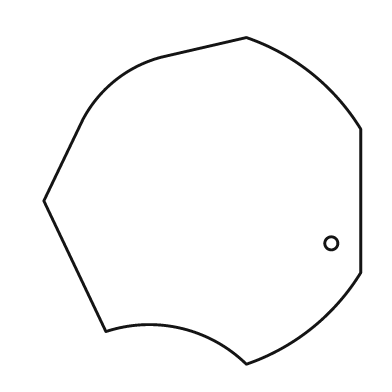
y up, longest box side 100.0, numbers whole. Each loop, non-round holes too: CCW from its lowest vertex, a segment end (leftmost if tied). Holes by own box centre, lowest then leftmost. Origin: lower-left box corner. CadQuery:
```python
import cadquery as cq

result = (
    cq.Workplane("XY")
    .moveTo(62.0, 0.0)
    .threePointArc((82.0, 11.0), (97.0, 28.0))
    .lineTo(97.0, 72.0)
    .threePointArc((82.0, 89.0), (62.0, 100.0))
    .lineTo(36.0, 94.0)
    .threePointArc((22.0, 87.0), (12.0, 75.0))
    .lineTo(0.0, 50.0)
    .lineTo(19.0, 10.0)
    .threePointArc((42.0, 11.0), (62.0, 0.0))
    .close()
    .moveTo(88.0, 37.0)
    .circle(2.0)
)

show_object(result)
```